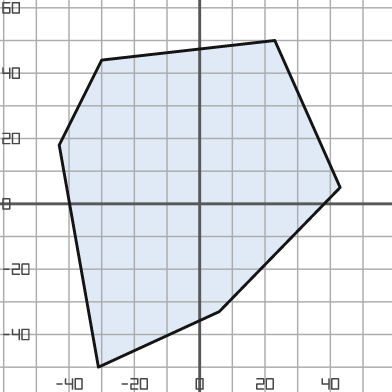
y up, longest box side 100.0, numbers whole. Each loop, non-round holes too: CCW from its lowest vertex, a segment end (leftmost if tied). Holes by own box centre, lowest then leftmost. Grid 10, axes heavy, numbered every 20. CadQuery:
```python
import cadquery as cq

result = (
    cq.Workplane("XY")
    .moveTo(-31.0, -50.0)
    .lineTo(6.0, -33.0)
    .lineTo(43.0, 5.0)
    .lineTo(23.0, 50.0)
    .lineTo(-30.0, 44.0)
    .lineTo(-43.0, 18.0)
    .close()
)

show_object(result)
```